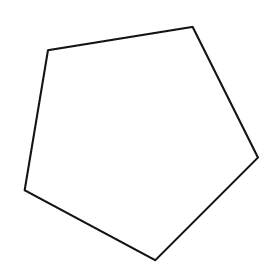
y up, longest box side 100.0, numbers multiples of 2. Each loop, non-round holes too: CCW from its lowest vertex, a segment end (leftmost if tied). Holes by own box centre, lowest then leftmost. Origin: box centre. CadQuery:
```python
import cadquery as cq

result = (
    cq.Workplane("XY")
    .moveTo(6.0, -50.0)
    .lineTo(50.0, -6.0)
    .lineTo(22.0, 50.0)
    .lineTo(-40.0, 40.0)
    .lineTo(-50.0, -20.0)
    .close()
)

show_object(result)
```